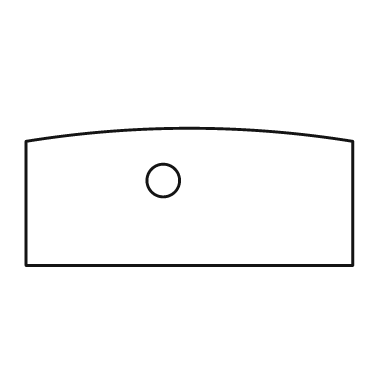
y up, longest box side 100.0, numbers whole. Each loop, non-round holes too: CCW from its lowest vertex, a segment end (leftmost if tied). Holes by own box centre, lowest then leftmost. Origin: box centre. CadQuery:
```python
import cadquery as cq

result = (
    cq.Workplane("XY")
    .moveTo(-50.0, -21.0)
    .lineTo(50.0, -21.0)
    .lineTo(50.0, 17.0)
    .threePointArc((0.0, 21.0), (-50.0, 17.0))
    .close()
    .moveTo(-8.0, 5.0)
    .circle(5.0)
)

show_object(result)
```